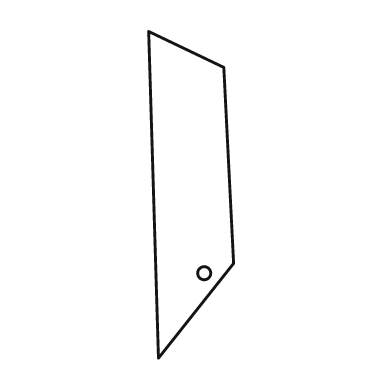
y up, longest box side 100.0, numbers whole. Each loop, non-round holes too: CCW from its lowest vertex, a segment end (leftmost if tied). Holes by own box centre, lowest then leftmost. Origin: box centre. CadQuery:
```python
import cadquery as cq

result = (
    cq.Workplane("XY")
    .moveTo(-10.0, -50.0)
    .lineTo(13.0, -21.0)
    .lineTo(10.0, 39.0)
    .lineTo(-13.0, 50.0)
    .close()
    .moveTo(4.0, -24.0)
    .circle(2.0)
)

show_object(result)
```